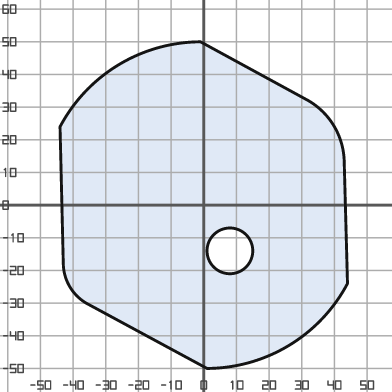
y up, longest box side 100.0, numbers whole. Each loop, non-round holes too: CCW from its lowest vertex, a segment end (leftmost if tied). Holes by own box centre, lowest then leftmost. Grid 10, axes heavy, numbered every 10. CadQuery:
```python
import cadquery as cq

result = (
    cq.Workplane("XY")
    .moveTo(1.0, -50.0)
    .threePointArc((26.0, -43.0), (44.0, -24.0))
    .lineTo(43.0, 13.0)
    .threePointArc((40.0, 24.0), (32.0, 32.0))
    .lineTo(-1.0, 50.0)
    .threePointArc((-26.0, 43.0), (-44.0, 24.0))
    .lineTo(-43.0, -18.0)
    .threePointArc((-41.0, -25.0), (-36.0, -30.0))
    .close()
    .moveTo(8.0, -14.0)
    .circle(7.0)
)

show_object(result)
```